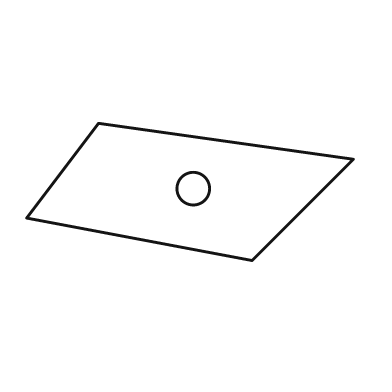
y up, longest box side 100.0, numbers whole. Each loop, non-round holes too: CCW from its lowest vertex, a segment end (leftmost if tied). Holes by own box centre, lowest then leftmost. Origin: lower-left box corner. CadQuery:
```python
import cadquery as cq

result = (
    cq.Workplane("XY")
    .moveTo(69.0, 0.0)
    .lineTo(100.0, 31.0)
    .lineTo(22.0, 42.0)
    .lineTo(0.0, 13.0)
    .close()
    .moveTo(51.0, 22.0)
    .circle(5.0)
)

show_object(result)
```